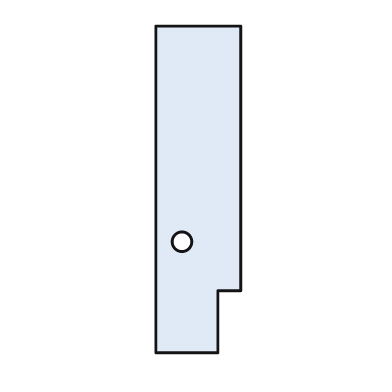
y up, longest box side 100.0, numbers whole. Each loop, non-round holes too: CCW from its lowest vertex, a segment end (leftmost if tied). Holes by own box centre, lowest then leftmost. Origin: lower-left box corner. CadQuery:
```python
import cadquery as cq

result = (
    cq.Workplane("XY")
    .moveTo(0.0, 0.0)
    .lineTo(19.0, 0.0)
    .lineTo(19.0, 19.0)
    .lineTo(26.0, 19.0)
    .lineTo(26.0, 100.0)
    .lineTo(0.0, 100.0)
    .close()
    .moveTo(8.0, 34.0)
    .circle(3.0)
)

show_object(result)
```